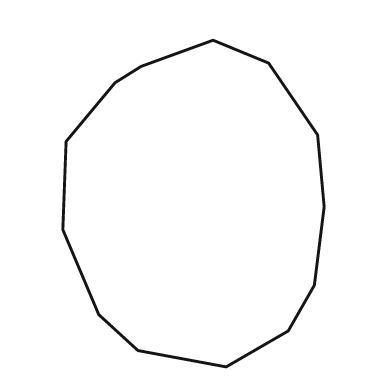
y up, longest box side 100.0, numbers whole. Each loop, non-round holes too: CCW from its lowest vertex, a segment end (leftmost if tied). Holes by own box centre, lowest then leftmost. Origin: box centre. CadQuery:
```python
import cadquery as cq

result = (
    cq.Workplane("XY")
    .moveTo(10.0, -50.0)
    .lineTo(29.0, -39.0)
    .lineTo(37.0, -25.0)
    .lineTo(40.0, -1.0)
    .lineTo(38.0, 21.0)
    .lineTo(23.0, 43.0)
    .lineTo(6.0, 50.0)
    .lineTo(-16.0, 42.0)
    .lineTo(-24.0, 37.0)
    .lineTo(-39.0, 19.0)
    .lineTo(-40.0, -8.0)
    .lineTo(-29.0, -34.0)
    .lineTo(-17.0, -45.0)
    .close()
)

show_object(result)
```